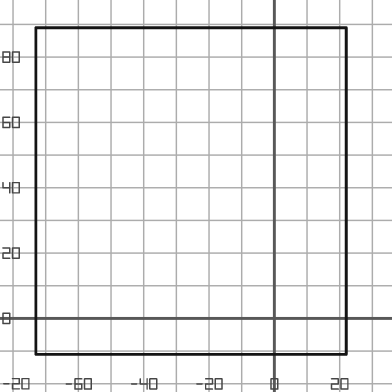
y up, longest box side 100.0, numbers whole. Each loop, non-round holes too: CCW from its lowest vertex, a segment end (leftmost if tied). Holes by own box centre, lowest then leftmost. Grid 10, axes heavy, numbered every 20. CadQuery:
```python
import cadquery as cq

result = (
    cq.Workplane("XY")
    .moveTo(-73.0, -11.0)
    .lineTo(22.0, -11.0)
    .lineTo(22.0, 89.0)
    .lineTo(-73.0, 89.0)
    .close()
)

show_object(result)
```